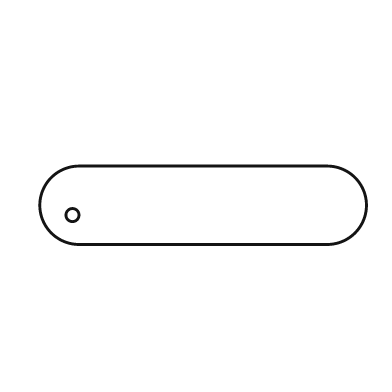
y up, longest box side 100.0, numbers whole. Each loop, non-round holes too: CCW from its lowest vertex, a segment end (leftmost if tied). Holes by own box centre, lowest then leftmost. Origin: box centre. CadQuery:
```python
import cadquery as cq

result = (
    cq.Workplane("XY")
    .moveTo(-38.0, -12.0)
    .lineTo(38.0, -12.0)
    .threePointArc((50.0, 0.0), (38.0, 12.0))
    .lineTo(-38.0, 12.0)
    .threePointArc((-50.0, 0.0), (-38.0, -12.0))
    .close()
    .moveTo(-40.0, -3.0)
    .circle(2.0)
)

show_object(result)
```